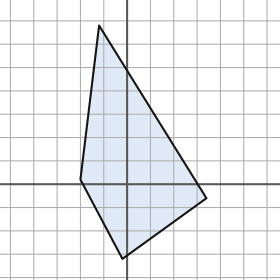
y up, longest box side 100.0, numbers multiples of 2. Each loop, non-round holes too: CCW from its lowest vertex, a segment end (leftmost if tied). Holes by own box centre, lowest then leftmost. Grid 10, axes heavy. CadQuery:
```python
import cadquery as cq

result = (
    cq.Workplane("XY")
    .moveTo(-2.0, -32.0)
    .lineTo(34.0, -6.0)
    .lineTo(-12.0, 68.0)
    .lineTo(-20.0, 2.0)
    .close()
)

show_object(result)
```